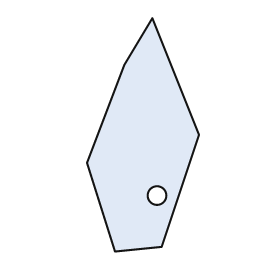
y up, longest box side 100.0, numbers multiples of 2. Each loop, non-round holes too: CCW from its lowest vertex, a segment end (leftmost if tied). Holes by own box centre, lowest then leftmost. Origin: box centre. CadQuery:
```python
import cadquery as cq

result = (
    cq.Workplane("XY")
    .moveTo(-12.0, -50.0)
    .lineTo(8.0, -48.0)
    .lineTo(24.0, 0.0)
    .lineTo(4.0, 50.0)
    .lineTo(-8.0, 30.0)
    .lineTo(-24.0, -12.0)
    .close()
    .moveTo(6.0, -26.0)
    .circle(4.0)
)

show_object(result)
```